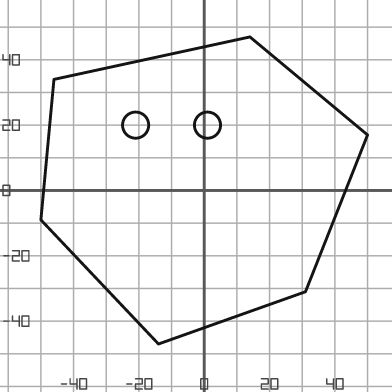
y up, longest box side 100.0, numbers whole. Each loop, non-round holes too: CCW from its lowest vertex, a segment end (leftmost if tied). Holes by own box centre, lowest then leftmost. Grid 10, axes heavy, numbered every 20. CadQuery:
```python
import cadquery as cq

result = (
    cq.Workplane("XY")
    .moveTo(-14.0, -47.0)
    .lineTo(31.0, -31.0)
    .lineTo(50.0, 17.0)
    .lineTo(14.0, 47.0)
    .lineTo(-46.0, 34.0)
    .lineTo(-50.0, -9.0)
    .close()
    .moveTo(-21.0, 20.0)
    .circle(4.0)
    .moveTo(1.0, 20.0)
    .circle(4.0)
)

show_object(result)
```